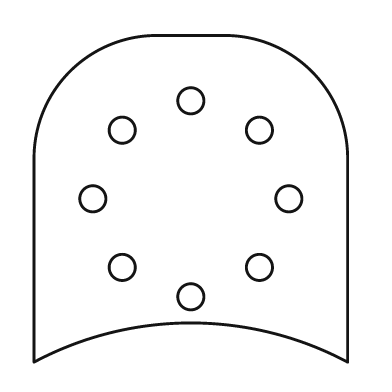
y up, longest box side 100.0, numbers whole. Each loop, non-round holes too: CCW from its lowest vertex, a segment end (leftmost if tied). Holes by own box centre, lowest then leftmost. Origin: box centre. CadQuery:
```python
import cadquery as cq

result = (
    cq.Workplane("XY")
    .moveTo(-48.0, -50.0)
    .threePointArc((0.0, -38.0), (48.0, -50.0))
    .lineTo(48.0, 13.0)
    .threePointArc((37.0, 39.0), (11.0, 50.0))
    .lineTo(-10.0, 50.0)
    .threePointArc((-37.0, 39.0), (-48.0, 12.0))
    .close()
    .moveTo(0.0, -30.0)
    .circle(4.0)
    .moveTo(-21.0, -21.0)
    .circle(4.0)
    .moveTo(21.0, -21.0)
    .circle(4.0)
    .moveTo(-30.0, 0.0)
    .circle(4.0)
    .moveTo(30.0, 0.0)
    .circle(4.0)
    .moveTo(-21.0, 21.0)
    .circle(4.0)
    .moveTo(21.0, 21.0)
    .circle(4.0)
    .moveTo(0.0, 30.0)
    .circle(4.0)
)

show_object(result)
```